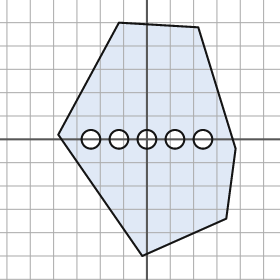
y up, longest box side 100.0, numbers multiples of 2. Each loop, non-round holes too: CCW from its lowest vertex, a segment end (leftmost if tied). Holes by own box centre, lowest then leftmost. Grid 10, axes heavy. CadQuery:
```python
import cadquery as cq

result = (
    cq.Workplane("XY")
    .moveTo(-2.0, -50.0)
    .lineTo(34.0, -34.0)
    .lineTo(38.0, -4.0)
    .lineTo(22.0, 48.0)
    .lineTo(-12.0, 50.0)
    .lineTo(-38.0, 2.0)
    .close()
    .moveTo(-24.0, 0.0)
    .circle(4.0)
    .moveTo(-12.0, 0.0)
    .circle(4.0)
    .moveTo(0.0, 0.0)
    .circle(4.0)
    .moveTo(12.0, 0.0)
    .circle(4.0)
    .moveTo(24.0, 0.0)
    .circle(4.0)
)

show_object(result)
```